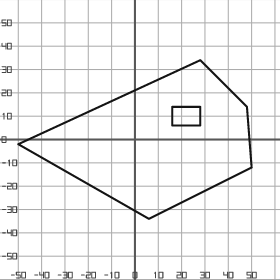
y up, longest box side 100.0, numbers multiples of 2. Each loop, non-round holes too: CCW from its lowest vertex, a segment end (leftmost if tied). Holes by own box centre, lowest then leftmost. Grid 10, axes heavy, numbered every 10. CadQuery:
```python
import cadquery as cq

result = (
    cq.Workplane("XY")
    .moveTo(6.0, -34.0)
    .lineTo(50.0, -12.0)
    .lineTo(48.0, 14.0)
    .lineTo(28.0, 34.0)
    .lineTo(-50.0, -2.0)
    .close()
    .moveTo(16.0, 6.0)
    .lineTo(28.0, 6.0)
    .lineTo(28.0, 14.0)
    .lineTo(16.0, 14.0)
    .close()
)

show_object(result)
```